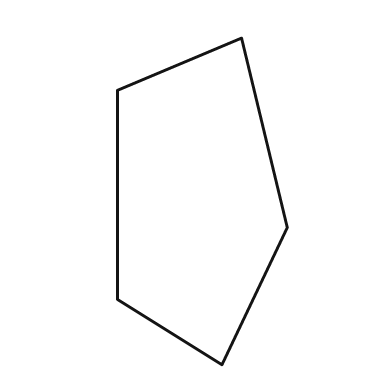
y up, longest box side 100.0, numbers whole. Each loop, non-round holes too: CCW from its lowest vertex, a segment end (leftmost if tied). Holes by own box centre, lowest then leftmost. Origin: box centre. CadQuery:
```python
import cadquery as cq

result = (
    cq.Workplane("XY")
    .moveTo(6.0, -50.0)
    .lineTo(26.0, -8.0)
    .lineTo(12.0, 50.0)
    .lineTo(-26.0, 34.0)
    .lineTo(-26.0, -30.0)
    .close()
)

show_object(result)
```